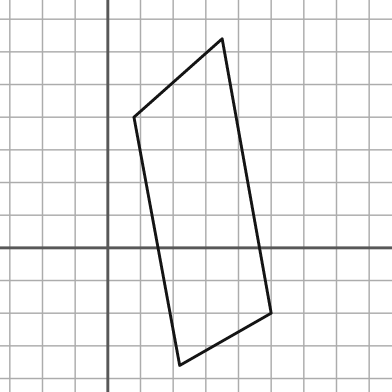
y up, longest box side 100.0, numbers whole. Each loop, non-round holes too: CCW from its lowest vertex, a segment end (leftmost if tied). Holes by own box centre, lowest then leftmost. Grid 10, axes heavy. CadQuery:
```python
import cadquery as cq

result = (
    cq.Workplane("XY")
    .moveTo(22.0, -36.0)
    .lineTo(50.0, -20.0)
    .lineTo(35.0, 64.0)
    .lineTo(8.0, 40.0)
    .close()
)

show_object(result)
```